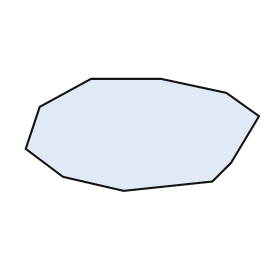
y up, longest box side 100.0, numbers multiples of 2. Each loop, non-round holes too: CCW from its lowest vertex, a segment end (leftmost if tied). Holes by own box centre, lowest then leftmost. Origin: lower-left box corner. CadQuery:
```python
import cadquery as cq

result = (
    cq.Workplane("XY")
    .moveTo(42.0, 0.0)
    .lineTo(80.0, 4.0)
    .lineTo(88.0, 12.0)
    .lineTo(100.0, 32.0)
    .lineTo(86.0, 42.0)
    .lineTo(58.0, 48.0)
    .lineTo(28.0, 48.0)
    .lineTo(6.0, 36.0)
    .lineTo(0.0, 18.0)
    .lineTo(16.0, 6.0)
    .close()
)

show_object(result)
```